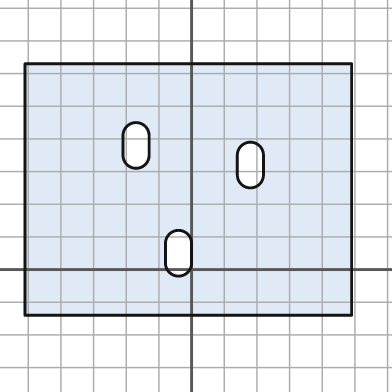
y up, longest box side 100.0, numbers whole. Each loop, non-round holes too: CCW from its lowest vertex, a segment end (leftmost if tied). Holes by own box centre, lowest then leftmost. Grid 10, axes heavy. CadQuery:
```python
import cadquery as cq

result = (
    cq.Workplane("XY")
    .moveTo(-51.0, -14.0)
    .lineTo(49.0, -14.0)
    .lineTo(49.0, 63.0)
    .lineTo(-51.0, 63.0)
    .close()
    .moveTo(-8.0, 2.0)
    .threePointArc((-4.0, -2.0), (0.0, 2.0))
    .lineTo(0.0, 8.0)
    .threePointArc((-4.0, 12.0), (-8.0, 8.0))
    .close()
    .moveTo(14.0, 29.0)
    .threePointArc((18.0, 25.0), (22.0, 29.0))
    .lineTo(22.0, 35.0)
    .threePointArc((18.0, 39.0), (14.0, 35.0))
    .close()
    .moveTo(-21.0, 35.0)
    .threePointArc((-17.0, 31.0), (-13.0, 35.0))
    .lineTo(-13.0, 41.0)
    .threePointArc((-17.0, 45.0), (-21.0, 41.0))
    .close()
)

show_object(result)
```